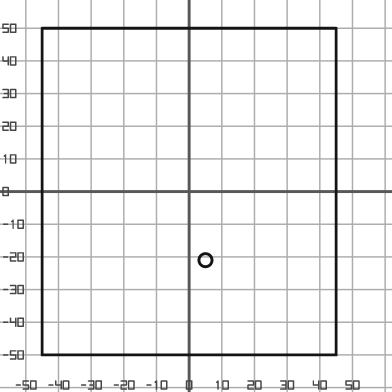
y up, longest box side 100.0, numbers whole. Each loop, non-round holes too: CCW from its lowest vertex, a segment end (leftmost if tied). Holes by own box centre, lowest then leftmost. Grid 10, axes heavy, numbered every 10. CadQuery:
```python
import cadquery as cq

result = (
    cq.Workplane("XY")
    .moveTo(-45.0, -50.0)
    .lineTo(45.0, -50.0)
    .lineTo(45.0, 50.0)
    .lineTo(-45.0, 50.0)
    .close()
    .moveTo(5.0, -21.0)
    .circle(2.0)
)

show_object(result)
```